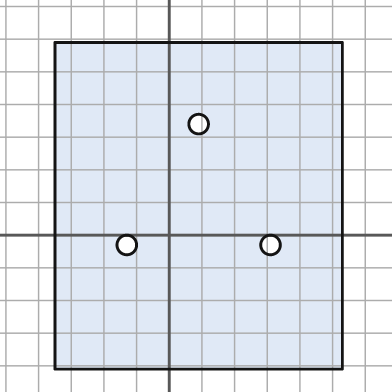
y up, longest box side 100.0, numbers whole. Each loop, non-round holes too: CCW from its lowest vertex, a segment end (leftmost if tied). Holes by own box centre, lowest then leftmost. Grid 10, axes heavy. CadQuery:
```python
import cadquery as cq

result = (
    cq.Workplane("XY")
    .moveTo(-35.0, -41.0)
    .lineTo(53.0, -41.0)
    .lineTo(53.0, 59.0)
    .lineTo(-35.0, 59.0)
    .close()
    .moveTo(-13.0, -3.0)
    .circle(3.0)
    .moveTo(31.0, -3.0)
    .circle(3.0)
    .moveTo(9.0, 34.0)
    .circle(3.0)
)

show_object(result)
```